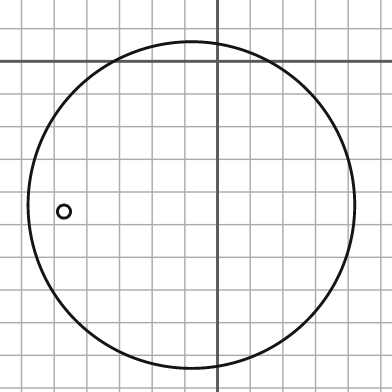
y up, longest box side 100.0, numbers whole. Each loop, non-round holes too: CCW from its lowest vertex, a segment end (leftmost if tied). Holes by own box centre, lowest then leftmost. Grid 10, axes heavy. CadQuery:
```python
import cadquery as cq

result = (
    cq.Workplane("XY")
    .moveTo(-8.0, -44.0)
    .circle(50.0)
    .moveTo(-47.0, -46.0)
    .circle(2.0)
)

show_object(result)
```